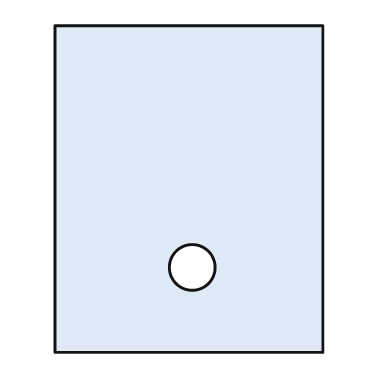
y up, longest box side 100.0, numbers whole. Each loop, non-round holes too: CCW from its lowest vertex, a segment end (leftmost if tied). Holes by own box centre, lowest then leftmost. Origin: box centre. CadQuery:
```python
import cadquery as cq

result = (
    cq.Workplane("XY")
    .moveTo(-41.0, -50.0)
    .lineTo(41.0, -50.0)
    .lineTo(41.0, 50.0)
    .lineTo(-41.0, 50.0)
    .close()
    .moveTo(1.0, -24.0)
    .circle(7.0)
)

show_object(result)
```